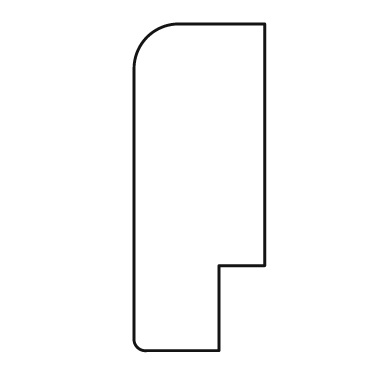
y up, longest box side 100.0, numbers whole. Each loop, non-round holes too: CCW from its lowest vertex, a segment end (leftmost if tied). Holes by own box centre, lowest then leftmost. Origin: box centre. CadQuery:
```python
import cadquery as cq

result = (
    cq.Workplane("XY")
    .moveTo(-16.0, -50.0)
    .lineTo(6.0, -50.0)
    .lineTo(6.0, -24.0)
    .lineTo(20.0, -24.0)
    .lineTo(20.0, 50.0)
    .lineTo(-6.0, 50.0)
    .threePointArc((-16.0, 46.0), (-20.0, 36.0))
    .lineTo(-20.0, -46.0)
    .threePointArc((-19.0, -49.0), (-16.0, -50.0))
    .close()
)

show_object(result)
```